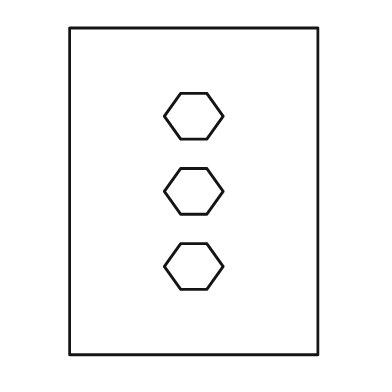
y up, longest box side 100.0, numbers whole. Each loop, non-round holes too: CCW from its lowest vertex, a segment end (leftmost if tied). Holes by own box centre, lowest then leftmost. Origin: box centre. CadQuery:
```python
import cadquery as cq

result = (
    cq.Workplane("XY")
    .moveTo(-38.0, -50.0)
    .lineTo(38.0, -50.0)
    .lineTo(38.0, 50.0)
    .lineTo(-38.0, 50.0)
    .close()
    .moveTo(-4.0, -30.0)
    .lineTo(4.0, -30.0)
    .lineTo(9.0, -23.0)
    .lineTo(4.0, -16.0)
    .lineTo(-4.0, -16.0)
    .lineTo(-9.0, -23.0)
    .close()
    .moveTo(-4.0, -7.0)
    .lineTo(4.0, -7.0)
    .lineTo(9.0, 0.0)
    .lineTo(4.0, 7.0)
    .lineTo(-4.0, 7.0)
    .lineTo(-9.0, 0.0)
    .close()
    .moveTo(-4.0, 16.0)
    .lineTo(4.0, 16.0)
    .lineTo(9.0, 23.0)
    .lineTo(4.0, 30.0)
    .lineTo(-4.0, 30.0)
    .lineTo(-9.0, 23.0)
    .close()
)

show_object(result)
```